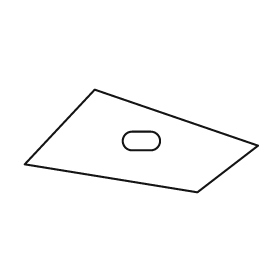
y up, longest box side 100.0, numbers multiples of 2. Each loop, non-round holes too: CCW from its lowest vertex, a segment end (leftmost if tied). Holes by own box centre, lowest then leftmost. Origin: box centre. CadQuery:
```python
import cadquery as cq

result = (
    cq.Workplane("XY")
    .moveTo(24.0, -22.0)
    .lineTo(50.0, -2.0)
    .lineTo(-20.0, 22.0)
    .lineTo(-50.0, -10.0)
    .close()
    .moveTo(-4.0, -4.0)
    .lineTo(4.0, -4.0)
    .threePointArc((8.0, 0.0), (4.0, 4.0))
    .lineTo(-4.0, 4.0)
    .threePointArc((-8.0, 0.0), (-4.0, -4.0))
    .close()
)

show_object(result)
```